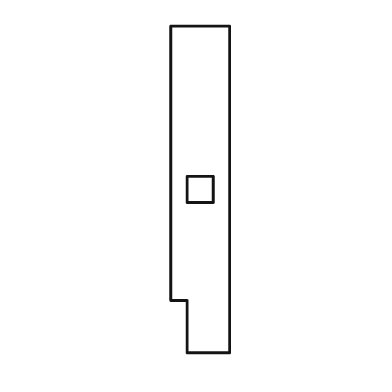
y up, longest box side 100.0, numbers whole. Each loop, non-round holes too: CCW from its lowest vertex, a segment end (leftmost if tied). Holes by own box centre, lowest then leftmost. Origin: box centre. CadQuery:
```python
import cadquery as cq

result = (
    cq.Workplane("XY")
    .moveTo(-4.0, -50.0)
    .lineTo(9.0, -50.0)
    .lineTo(9.0, 50.0)
    .lineTo(-9.0, 50.0)
    .lineTo(-9.0, -34.0)
    .lineTo(-4.0, -34.0)
    .close()
    .moveTo(-4.0, -4.0)
    .lineTo(4.0, -4.0)
    .lineTo(4.0, 4.0)
    .lineTo(-4.0, 4.0)
    .close()
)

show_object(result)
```